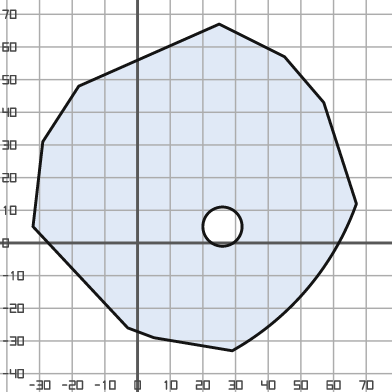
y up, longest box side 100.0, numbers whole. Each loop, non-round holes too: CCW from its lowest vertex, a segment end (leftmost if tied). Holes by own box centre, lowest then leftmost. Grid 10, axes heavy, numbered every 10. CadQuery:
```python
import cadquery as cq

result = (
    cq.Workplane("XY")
    .moveTo(29.0, -33.0)
    .threePointArc((52.0, -14.0), (67.0, 12.0))
    .lineTo(57.0, 43.0)
    .lineTo(45.0, 57.0)
    .lineTo(25.0, 67.0)
    .lineTo(-18.0, 48.0)
    .lineTo(-29.0, 31.0)
    .lineTo(-32.0, 5.0)
    .lineTo(-3.0, -26.0)
    .lineTo(5.0, -29.0)
    .close()
    .moveTo(26.0, 5.0)
    .circle(6.0)
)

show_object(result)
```